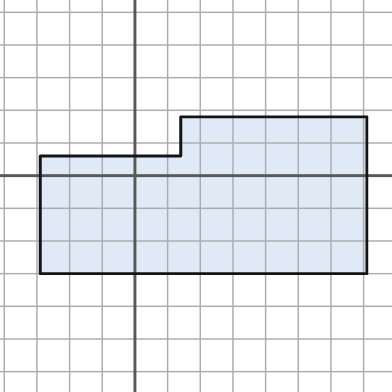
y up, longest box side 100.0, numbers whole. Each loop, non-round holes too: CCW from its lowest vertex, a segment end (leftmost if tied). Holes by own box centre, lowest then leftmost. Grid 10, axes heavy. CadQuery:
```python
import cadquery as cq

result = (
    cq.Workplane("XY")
    .moveTo(-29.0, -30.0)
    .lineTo(71.0, -30.0)
    .lineTo(71.0, 18.0)
    .lineTo(14.0, 18.0)
    .lineTo(14.0, 6.0)
    .lineTo(-29.0, 6.0)
    .close()
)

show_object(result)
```